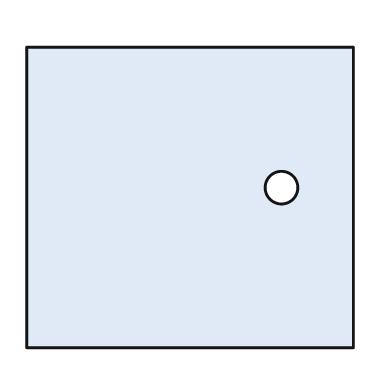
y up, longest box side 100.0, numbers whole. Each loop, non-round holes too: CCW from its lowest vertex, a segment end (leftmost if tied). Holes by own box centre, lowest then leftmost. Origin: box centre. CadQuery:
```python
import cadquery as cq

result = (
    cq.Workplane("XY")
    .moveTo(-50.0, -46.0)
    .lineTo(50.0, -46.0)
    .lineTo(50.0, 46.0)
    .lineTo(-50.0, 46.0)
    .close()
    .moveTo(28.0, 3.0)
    .circle(5.0)
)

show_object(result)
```